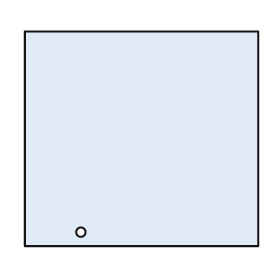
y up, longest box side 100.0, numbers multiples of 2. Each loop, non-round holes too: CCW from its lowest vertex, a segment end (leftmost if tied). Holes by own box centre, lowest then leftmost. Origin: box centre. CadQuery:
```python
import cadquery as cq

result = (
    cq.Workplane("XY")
    .moveTo(-50.0, -46.0)
    .lineTo(50.0, -46.0)
    .lineTo(50.0, 46.0)
    .lineTo(-50.0, 46.0)
    .close()
    .moveTo(-26.0, -40.0)
    .circle(2.0)
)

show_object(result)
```